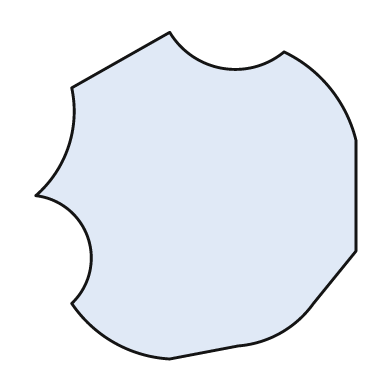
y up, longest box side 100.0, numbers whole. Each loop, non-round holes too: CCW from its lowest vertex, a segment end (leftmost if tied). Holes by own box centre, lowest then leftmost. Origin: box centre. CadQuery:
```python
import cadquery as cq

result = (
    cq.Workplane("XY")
    .moveTo(-8.0, -50.0)
    .lineTo(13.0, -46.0)
    .threePointArc((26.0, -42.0), (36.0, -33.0))
    .lineTo(49.0, -17.0)
    .lineTo(49.0, 17.0)
    .threePointArc((41.0, 33.0), (27.0, 44.0))
    .threePointArc((8.0, 39.0), (-8.0, 50.0))
    .lineTo(-38.0, 33.0)
    .threePointArc((-39.0, 15.0), (-49.0, 0.0))
    .threePointArc((-33.0, -13.0), (-38.0, -33.0))
    .threePointArc((-25.0, -45.0), (-8.0, -50.0))
    .close()
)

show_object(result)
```